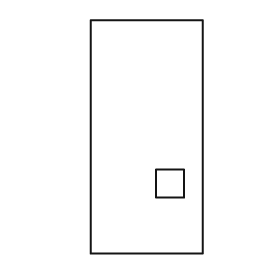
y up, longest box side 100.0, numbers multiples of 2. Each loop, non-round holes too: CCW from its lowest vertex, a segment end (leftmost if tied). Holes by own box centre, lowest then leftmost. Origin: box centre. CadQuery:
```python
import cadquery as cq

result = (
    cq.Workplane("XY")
    .moveTo(-24.0, -50.0)
    .lineTo(24.0, -50.0)
    .lineTo(24.0, 50.0)
    .lineTo(-24.0, 50.0)
    .close()
    .moveTo(4.0, -26.0)
    .lineTo(16.0, -26.0)
    .lineTo(16.0, -14.0)
    .lineTo(4.0, -14.0)
    .close()
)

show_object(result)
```